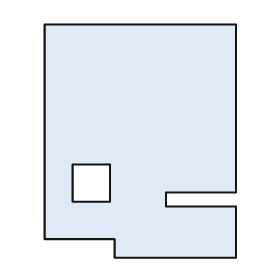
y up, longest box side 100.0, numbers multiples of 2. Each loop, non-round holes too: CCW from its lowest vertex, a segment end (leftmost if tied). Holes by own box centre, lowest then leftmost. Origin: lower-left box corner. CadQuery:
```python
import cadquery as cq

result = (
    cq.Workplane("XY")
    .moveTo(30.0, 0.0)
    .lineTo(82.0, 0.0)
    .lineTo(82.0, 22.0)
    .lineTo(52.0, 22.0)
    .lineTo(52.0, 28.0)
    .lineTo(82.0, 28.0)
    .lineTo(82.0, 100.0)
    .lineTo(0.0, 100.0)
    .lineTo(0.0, 8.0)
    .lineTo(30.0, 8.0)
    .close()
    .moveTo(12.0, 24.0)
    .lineTo(28.0, 24.0)
    .lineTo(28.0, 40.0)
    .lineTo(12.0, 40.0)
    .close()
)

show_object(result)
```